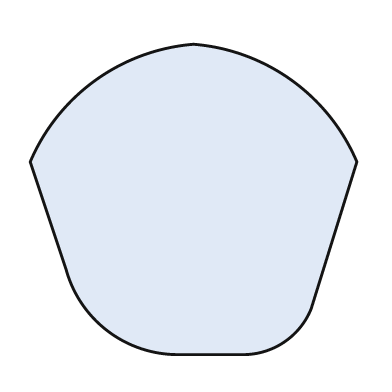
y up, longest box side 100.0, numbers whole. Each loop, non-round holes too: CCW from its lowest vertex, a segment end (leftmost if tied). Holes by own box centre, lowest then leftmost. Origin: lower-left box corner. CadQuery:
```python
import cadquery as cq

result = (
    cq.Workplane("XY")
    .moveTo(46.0, 0.0)
    .lineTo(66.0, 0.0)
    .threePointArc((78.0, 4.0), (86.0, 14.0))
    .lineTo(100.0, 59.0)
    .threePointArc((80.0, 84.0), (50.0, 95.0))
    .threePointArc((20.0, 84.0), (0.0, 59.0))
    .lineTo(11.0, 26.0)
    .threePointArc((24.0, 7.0), (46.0, 0.0))
    .close()
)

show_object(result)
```